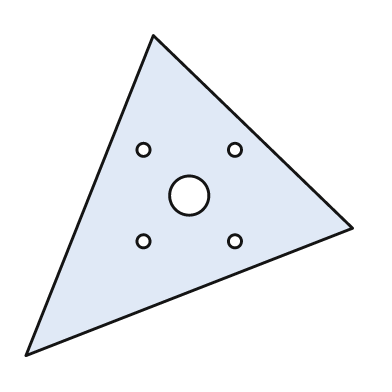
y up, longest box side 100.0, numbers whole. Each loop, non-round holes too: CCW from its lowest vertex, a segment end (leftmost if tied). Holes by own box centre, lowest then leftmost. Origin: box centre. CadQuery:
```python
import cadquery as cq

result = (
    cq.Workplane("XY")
    .moveTo(-50.0, -49.0)
    .lineTo(50.0, -10.0)
    .lineTo(-11.0, 49.0)
    .close()
    .moveTo(-14.0, -14.0)
    .circle(2.0)
    .moveTo(14.0, -14.0)
    .circle(2.0)
    .moveTo(0.0, 0.0)
    .circle(6.0)
    .moveTo(-14.0, 14.0)
    .circle(2.0)
    .moveTo(14.0, 14.0)
    .circle(2.0)
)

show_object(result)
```